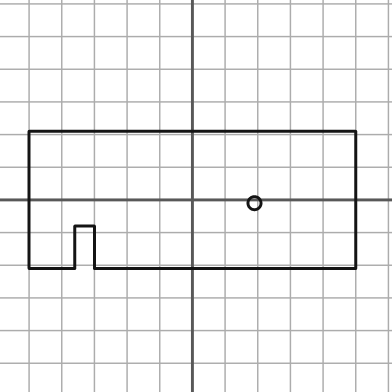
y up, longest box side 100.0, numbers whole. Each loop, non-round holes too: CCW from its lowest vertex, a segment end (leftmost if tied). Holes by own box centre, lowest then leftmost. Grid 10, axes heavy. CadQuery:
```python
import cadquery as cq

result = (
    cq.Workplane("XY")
    .moveTo(-50.0, -21.0)
    .lineTo(-36.0, -21.0)
    .lineTo(-36.0, -8.0)
    .lineTo(-30.0, -8.0)
    .lineTo(-30.0, -21.0)
    .lineTo(50.0, -21.0)
    .lineTo(50.0, 21.0)
    .lineTo(-50.0, 21.0)
    .close()
    .moveTo(19.0, -1.0)
    .circle(2.0)
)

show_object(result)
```